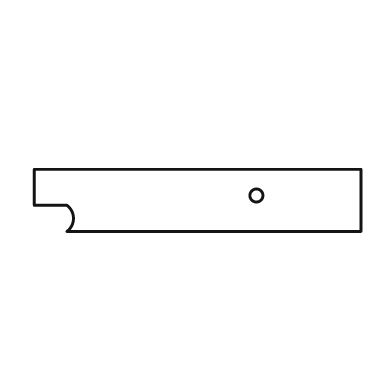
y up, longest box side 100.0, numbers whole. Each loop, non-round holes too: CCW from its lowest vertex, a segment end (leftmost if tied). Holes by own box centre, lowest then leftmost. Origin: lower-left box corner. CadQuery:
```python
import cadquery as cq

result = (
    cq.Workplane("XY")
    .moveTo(10.0, 0.0)
    .lineTo(100.0, 0.0)
    .lineTo(100.0, 19.0)
    .lineTo(0.0, 19.0)
    .lineTo(0.0, 8.0)
    .lineTo(10.0, 8.0)
    .threePointArc((12.0, 4.0), (10.0, 0.0))
    .close()
    .moveTo(68.0, 11.0)
    .circle(2.0)
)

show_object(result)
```